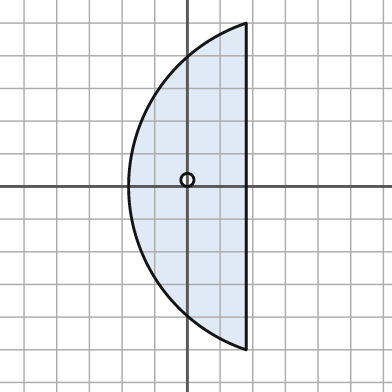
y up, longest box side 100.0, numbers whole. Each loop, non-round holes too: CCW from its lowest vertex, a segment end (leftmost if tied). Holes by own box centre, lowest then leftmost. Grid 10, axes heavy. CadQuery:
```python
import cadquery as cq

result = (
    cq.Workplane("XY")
    .moveTo(18.0, -50.0)
    .lineTo(18.0, 50.0)
    .threePointArc((-18.0, 0.0), (18.0, -50.0))
    .close()
    .moveTo(0.0, 2.0)
    .circle(2.0)
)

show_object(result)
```